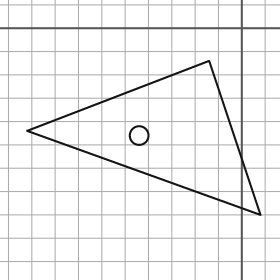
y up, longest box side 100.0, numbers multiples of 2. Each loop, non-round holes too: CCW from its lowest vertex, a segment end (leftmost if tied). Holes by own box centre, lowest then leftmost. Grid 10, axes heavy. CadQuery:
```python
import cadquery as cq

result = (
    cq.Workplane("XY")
    .moveTo(8.0, -80.0)
    .lineTo(-14.0, -14.0)
    .lineTo(-92.0, -44.0)
    .close()
    .moveTo(-44.0, -46.0)
    .circle(4.0)
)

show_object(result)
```